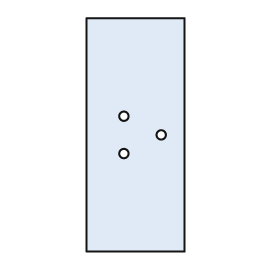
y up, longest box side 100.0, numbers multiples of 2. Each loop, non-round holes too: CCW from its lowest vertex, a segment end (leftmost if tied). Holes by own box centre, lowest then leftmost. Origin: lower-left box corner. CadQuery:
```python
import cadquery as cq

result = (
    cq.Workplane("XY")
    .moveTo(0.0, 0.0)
    .lineTo(42.0, 0.0)
    .lineTo(42.0, 100.0)
    .lineTo(0.0, 100.0)
    .close()
    .moveTo(16.0, 42.0)
    .circle(2.0)
    .moveTo(32.0, 50.0)
    .circle(2.0)
    .moveTo(16.0, 58.0)
    .circle(2.0)
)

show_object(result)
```